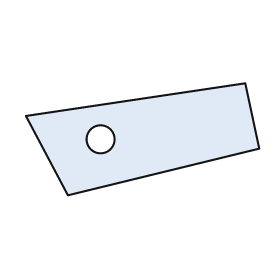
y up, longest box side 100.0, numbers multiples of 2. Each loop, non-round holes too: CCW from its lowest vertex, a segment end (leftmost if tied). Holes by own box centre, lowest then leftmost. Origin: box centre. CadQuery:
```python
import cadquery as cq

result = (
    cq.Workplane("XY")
    .moveTo(-32.0, -24.0)
    .lineTo(50.0, -4.0)
    .lineTo(44.0, 24.0)
    .lineTo(-50.0, 10.0)
    .close()
    .moveTo(-18.0, 0.0)
    .circle(6.0)
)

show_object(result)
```